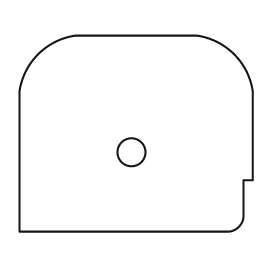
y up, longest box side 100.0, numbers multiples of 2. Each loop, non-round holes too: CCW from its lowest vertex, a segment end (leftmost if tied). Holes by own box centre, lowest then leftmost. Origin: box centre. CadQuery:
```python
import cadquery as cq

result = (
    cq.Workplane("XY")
    .moveTo(-50.0, -42.0)
    .lineTo(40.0, -42.0)
    .threePointArc((44.0, -40.0), (46.0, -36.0))
    .lineTo(46.0, -20.0)
    .lineTo(50.0, -20.0)
    .lineTo(50.0, 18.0)
    .threePointArc((42.0, 34.0), (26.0, 42.0))
    .lineTo(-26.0, 42.0)
    .threePointArc((-42.0, 34.0), (-50.0, 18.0))
    .close()
    .moveTo(-2.0, -8.0)
    .circle(6.0)
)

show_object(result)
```